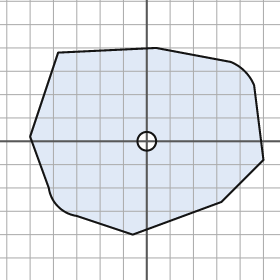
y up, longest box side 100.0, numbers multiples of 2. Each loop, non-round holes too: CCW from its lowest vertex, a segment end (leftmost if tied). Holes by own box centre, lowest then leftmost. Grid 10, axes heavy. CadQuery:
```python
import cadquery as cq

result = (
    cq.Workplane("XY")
    .moveTo(-6.0, -40.0)
    .lineTo(32.0, -26.0)
    .lineTo(50.0, -8.0)
    .lineTo(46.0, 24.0)
    .threePointArc((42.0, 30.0), (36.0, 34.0))
    .lineTo(4.0, 40.0)
    .lineTo(-38.0, 38.0)
    .lineTo(-50.0, 2.0)
    .lineTo(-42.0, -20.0)
    .threePointArc((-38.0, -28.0), (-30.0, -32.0))
    .close()
    .moveTo(0.0, 0.0)
    .circle(4.0)
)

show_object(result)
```